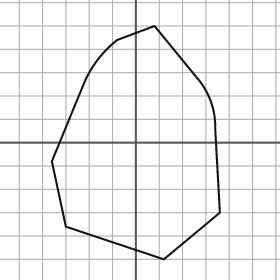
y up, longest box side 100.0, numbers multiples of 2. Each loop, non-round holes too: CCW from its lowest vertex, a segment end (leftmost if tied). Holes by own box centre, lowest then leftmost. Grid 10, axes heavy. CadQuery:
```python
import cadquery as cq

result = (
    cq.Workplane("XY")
    .moveTo(12.0, -50.0)
    .lineTo(36.0, -30.0)
    .lineTo(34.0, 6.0)
    .threePointArc((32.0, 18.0), (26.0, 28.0))
    .lineTo(8.0, 50.0)
    .lineTo(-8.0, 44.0)
    .threePointArc((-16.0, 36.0), (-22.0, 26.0))
    .lineTo(-36.0, -8.0)
    .lineTo(-30.0, -36.0)
    .close()
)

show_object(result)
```